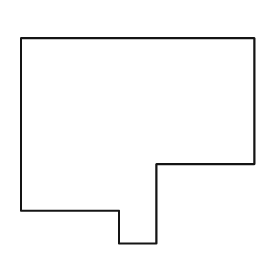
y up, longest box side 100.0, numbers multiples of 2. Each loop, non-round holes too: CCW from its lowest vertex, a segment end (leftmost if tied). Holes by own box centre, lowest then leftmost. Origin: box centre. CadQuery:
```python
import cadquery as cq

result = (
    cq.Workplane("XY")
    .moveTo(-8.0, -44.0)
    .lineTo(8.0, -44.0)
    .lineTo(8.0, -10.0)
    .lineTo(50.0, -10.0)
    .lineTo(50.0, 44.0)
    .lineTo(-50.0, 44.0)
    .lineTo(-50.0, -30.0)
    .lineTo(-8.0, -30.0)
    .close()
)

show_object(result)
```